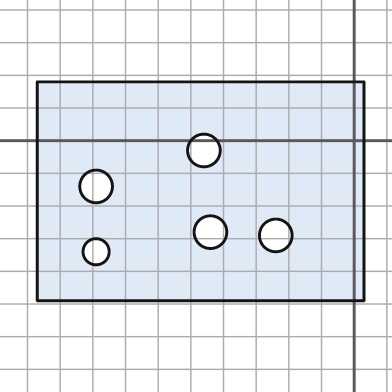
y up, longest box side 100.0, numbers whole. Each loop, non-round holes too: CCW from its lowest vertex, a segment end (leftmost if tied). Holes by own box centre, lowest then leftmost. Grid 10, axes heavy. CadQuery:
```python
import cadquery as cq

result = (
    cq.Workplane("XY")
    .moveTo(-97.0, -49.0)
    .lineTo(3.0, -49.0)
    .lineTo(3.0, 18.0)
    .lineTo(-97.0, 18.0)
    .close()
    .moveTo(-79.0, -34.0)
    .circle(4.0)
    .moveTo(-24.0, -29.0)
    .circle(5.0)
    .moveTo(-44.0, -28.0)
    .circle(5.0)
    .moveTo(-79.0, -14.0)
    .circle(5.0)
    .moveTo(-46.0, -3.0)
    .circle(5.0)
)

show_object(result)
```